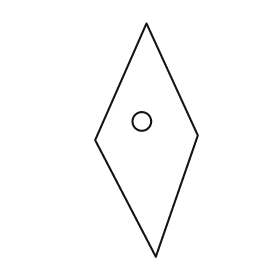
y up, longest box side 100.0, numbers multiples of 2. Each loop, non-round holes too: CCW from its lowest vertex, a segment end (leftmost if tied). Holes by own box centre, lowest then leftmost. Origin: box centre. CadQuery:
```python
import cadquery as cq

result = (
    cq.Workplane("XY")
    .moveTo(4.0, -50.0)
    .lineTo(22.0, 2.0)
    .lineTo(0.0, 50.0)
    .lineTo(-22.0, 0.0)
    .close()
    .moveTo(-2.0, 8.0)
    .circle(4.0)
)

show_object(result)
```